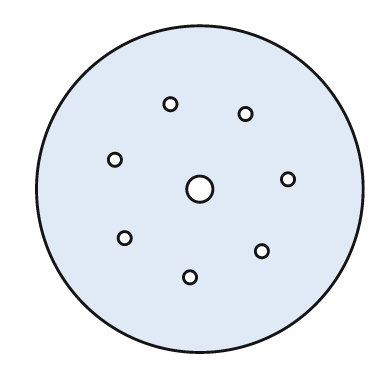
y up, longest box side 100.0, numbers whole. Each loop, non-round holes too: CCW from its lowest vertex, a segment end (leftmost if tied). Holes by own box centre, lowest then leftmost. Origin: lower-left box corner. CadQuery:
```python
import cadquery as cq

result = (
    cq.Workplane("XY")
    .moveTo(50.0, 50.0)
    .circle(50.0)
    .moveTo(47.0, 23.0)
    .circle(2.0)
    .moveTo(69.0, 31.0)
    .circle(2.0)
    .moveTo(27.0, 35.0)
    .circle(2.0)
    .moveTo(50.0, 50.0)
    .circle(4.0)
    .moveTo(77.0, 53.0)
    .circle(2.0)
    .moveTo(24.0, 59.0)
    .circle(2.0)
    .moveTo(64.0, 73.0)
    .circle(2.0)
    .moveTo(41.0, 76.0)
    .circle(2.0)
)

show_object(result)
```